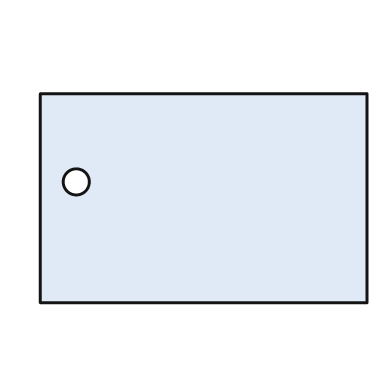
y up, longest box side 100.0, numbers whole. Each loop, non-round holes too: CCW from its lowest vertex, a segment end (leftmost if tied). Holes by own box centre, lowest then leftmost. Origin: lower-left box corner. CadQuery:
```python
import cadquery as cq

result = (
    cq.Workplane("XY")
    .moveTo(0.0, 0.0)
    .lineTo(100.0, 0.0)
    .lineTo(100.0, 64.0)
    .lineTo(0.0, 64.0)
    .close()
    .moveTo(11.0, 37.0)
    .circle(4.0)
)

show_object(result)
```